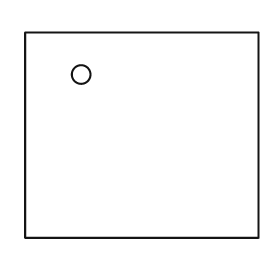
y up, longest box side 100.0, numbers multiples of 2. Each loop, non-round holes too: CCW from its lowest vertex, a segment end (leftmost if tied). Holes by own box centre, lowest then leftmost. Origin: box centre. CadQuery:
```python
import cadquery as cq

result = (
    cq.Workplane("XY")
    .moveTo(-50.0, -44.0)
    .lineTo(50.0, -44.0)
    .lineTo(50.0, 44.0)
    .lineTo(-50.0, 44.0)
    .close()
    .moveTo(-26.0, 26.0)
    .circle(4.0)
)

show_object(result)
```